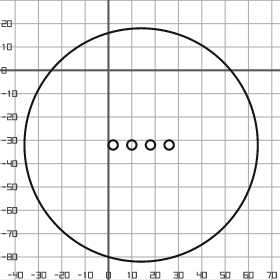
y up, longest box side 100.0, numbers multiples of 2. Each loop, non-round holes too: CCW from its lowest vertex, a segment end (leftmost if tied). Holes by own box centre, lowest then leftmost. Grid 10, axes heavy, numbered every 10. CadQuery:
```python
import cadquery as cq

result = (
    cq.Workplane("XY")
    .moveTo(14.0, -32.0)
    .circle(50.0)
    .moveTo(2.0, -32.0)
    .circle(2.0)
    .moveTo(10.0, -32.0)
    .circle(2.0)
    .moveTo(18.0, -32.0)
    .circle(2.0)
    .moveTo(26.0, -32.0)
    .circle(2.0)
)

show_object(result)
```